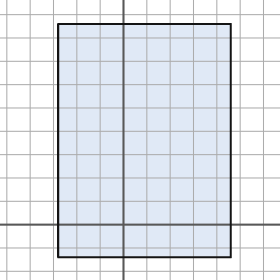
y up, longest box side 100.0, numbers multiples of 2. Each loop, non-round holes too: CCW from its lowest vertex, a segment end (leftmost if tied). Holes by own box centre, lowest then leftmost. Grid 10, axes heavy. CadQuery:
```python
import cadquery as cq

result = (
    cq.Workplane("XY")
    .moveTo(-28.0, -14.0)
    .lineTo(46.0, -14.0)
    .lineTo(46.0, 86.0)
    .lineTo(-28.0, 86.0)
    .close()
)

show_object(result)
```